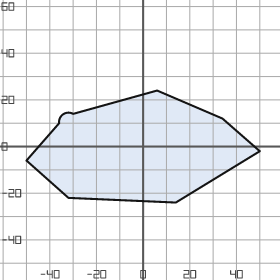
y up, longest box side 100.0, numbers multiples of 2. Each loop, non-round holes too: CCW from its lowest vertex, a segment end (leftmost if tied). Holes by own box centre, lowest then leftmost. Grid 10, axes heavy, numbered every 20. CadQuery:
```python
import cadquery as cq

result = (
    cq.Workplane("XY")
    .moveTo(14.0, -24.0)
    .lineTo(50.0, -2.0)
    .lineTo(34.0, 12.0)
    .lineTo(6.0, 24.0)
    .lineTo(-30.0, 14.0)
    .threePointArc((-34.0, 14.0), (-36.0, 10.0))
    .lineTo(-50.0, -6.0)
    .lineTo(-32.0, -22.0)
    .close()
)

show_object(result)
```